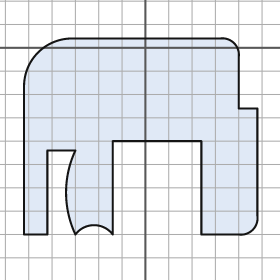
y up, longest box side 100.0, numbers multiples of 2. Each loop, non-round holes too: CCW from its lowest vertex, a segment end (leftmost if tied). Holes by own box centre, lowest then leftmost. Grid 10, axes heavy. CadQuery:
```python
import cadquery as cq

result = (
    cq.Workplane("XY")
    .moveTo(-52.0, -80.0)
    .lineTo(-42.0, -80.0)
    .lineTo(-42.0, -44.0)
    .lineTo(-30.0, -44.0)
    .threePointArc((-34.0, -62.0), (-30.0, -80.0))
    .threePointArc((-22.0, -76.0), (-14.0, -80.0))
    .lineTo(-14.0, -40.0)
    .lineTo(24.0, -40.0)
    .lineTo(24.0, -80.0)
    .lineTo(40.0, -80.0)
    .threePointArc((46.0, -78.0), (48.0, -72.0))
    .lineTo(48.0, -26.0)
    .lineTo(40.0, -26.0)
    .lineTo(40.0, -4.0)
    .threePointArc((38.0, 2.0), (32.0, 4.0))
    .lineTo(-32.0, 4.0)
    .threePointArc((-46.0, -2.0), (-52.0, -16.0))
    .close()
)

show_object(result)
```